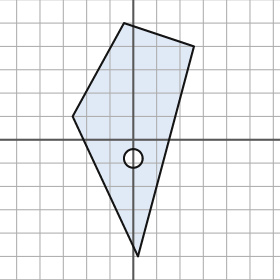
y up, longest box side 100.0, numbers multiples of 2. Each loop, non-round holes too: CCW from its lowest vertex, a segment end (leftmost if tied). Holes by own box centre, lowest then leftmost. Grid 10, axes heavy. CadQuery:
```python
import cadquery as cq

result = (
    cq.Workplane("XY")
    .moveTo(2.0, -50.0)
    .lineTo(26.0, 40.0)
    .lineTo(-4.0, 50.0)
    .lineTo(-26.0, 10.0)
    .close()
    .moveTo(0.0, -8.0)
    .circle(4.0)
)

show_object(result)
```